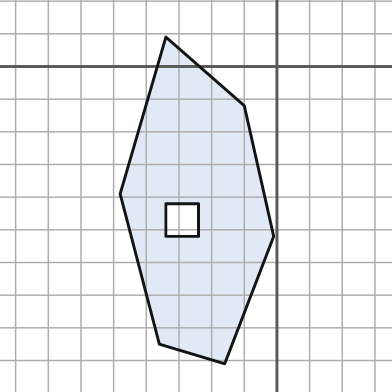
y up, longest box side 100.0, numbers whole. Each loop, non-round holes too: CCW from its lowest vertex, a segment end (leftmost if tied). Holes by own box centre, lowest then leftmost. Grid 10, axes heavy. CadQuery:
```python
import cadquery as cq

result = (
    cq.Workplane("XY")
    .moveTo(-16.0, -91.0)
    .lineTo(-1.0, -52.0)
    .lineTo(-10.0, -12.0)
    .lineTo(-34.0, 9.0)
    .lineTo(-48.0, -39.0)
    .lineTo(-36.0, -85.0)
    .close()
    .moveTo(-34.0, -52.0)
    .lineTo(-24.0, -52.0)
    .lineTo(-24.0, -42.0)
    .lineTo(-34.0, -42.0)
    .close()
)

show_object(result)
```